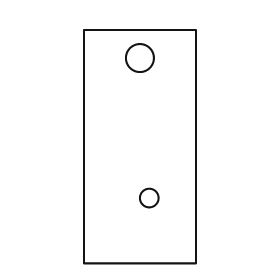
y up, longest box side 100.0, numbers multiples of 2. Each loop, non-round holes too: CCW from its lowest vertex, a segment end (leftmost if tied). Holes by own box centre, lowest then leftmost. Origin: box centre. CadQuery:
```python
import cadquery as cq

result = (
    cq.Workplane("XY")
    .moveTo(-24.0, -50.0)
    .lineTo(24.0, -50.0)
    .lineTo(24.0, 50.0)
    .lineTo(-24.0, 50.0)
    .close()
    .moveTo(4.0, -22.0)
    .circle(4.0)
    .moveTo(0.0, 38.0)
    .circle(6.0)
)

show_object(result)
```